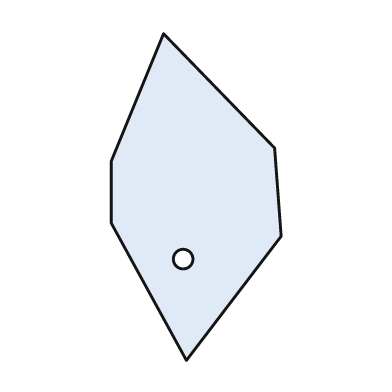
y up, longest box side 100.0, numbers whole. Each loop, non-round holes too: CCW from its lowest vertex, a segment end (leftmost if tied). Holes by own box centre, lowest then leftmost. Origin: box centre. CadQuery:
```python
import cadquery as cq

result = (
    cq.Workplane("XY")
    .moveTo(-3.0, -50.0)
    .lineTo(26.0, -12.0)
    .lineTo(24.0, 15.0)
    .lineTo(-10.0, 50.0)
    .lineTo(-26.0, 11.0)
    .lineTo(-26.0, -8.0)
    .close()
    .moveTo(-4.0, -19.0)
    .circle(3.0)
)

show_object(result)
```